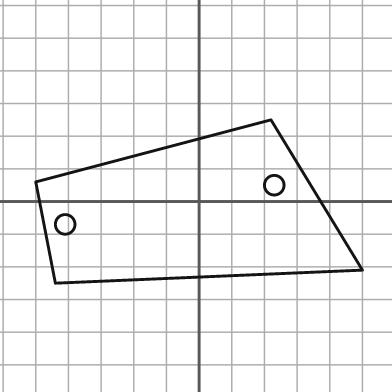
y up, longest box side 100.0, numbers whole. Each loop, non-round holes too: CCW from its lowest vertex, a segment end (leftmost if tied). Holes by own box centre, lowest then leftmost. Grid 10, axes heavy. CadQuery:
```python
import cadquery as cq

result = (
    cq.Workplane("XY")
    .moveTo(-44.0, -25.0)
    .lineTo(50.0, -21.0)
    .lineTo(22.0, 25.0)
    .lineTo(-50.0, 6.0)
    .close()
    .moveTo(-41.0, -7.0)
    .circle(3.0)
    .moveTo(23.0, 5.0)
    .circle(3.0)
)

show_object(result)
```